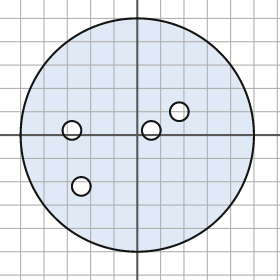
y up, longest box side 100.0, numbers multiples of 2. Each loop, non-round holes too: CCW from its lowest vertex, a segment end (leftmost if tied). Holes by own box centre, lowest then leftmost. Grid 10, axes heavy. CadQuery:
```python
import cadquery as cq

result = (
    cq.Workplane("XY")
    .moveTo(0.0, 0.0)
    .circle(50.0)
    .moveTo(-24.0, -22.0)
    .circle(4.0)
    .moveTo(-28.0, 2.0)
    .circle(4.0)
    .moveTo(6.0, 2.0)
    .circle(4.0)
    .moveTo(18.0, 10.0)
    .circle(4.0)
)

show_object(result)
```